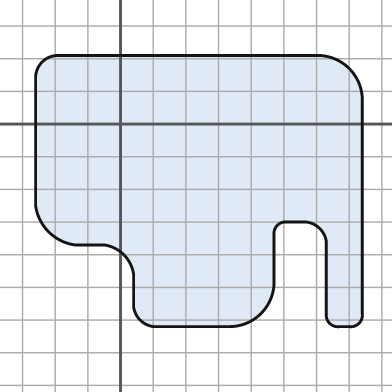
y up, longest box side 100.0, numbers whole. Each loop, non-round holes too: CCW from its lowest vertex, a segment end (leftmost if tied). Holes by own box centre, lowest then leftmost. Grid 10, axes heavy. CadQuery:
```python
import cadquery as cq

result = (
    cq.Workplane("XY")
    .moveTo(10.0, -62.0)
    .lineTo(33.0, -62.0)
    .threePointArc((43.0, -58.0), (47.0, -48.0))
    .lineTo(47.0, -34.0)
    .threePointArc((48.0, -31.0), (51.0, -30.0))
    .lineTo(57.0, -30.0)
    .threePointArc((61.0, -32.0), (63.0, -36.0))
    .lineTo(63.0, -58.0)
    .threePointArc((64.0, -61.0), (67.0, -62.0))
    .lineTo(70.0, -62.0)
    .threePointArc((73.0, -61.0), (74.0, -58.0))
    .lineTo(74.0, 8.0)
    .threePointArc((70.0, 17.0), (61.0, 21.0))
    .lineTo(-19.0, 21.0)
    .threePointArc((-24.0, 19.0), (-26.0, 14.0))
    .lineTo(-26.0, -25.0)
    .threePointArc((-22.0, -33.0), (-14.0, -37.0))
    .lineTo(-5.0, -37.0)
    .threePointArc((1.0, -40.0), (4.0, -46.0))
    .lineTo(4.0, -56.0)
    .threePointArc((6.0, -60.0), (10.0, -62.0))
    .close()
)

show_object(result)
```